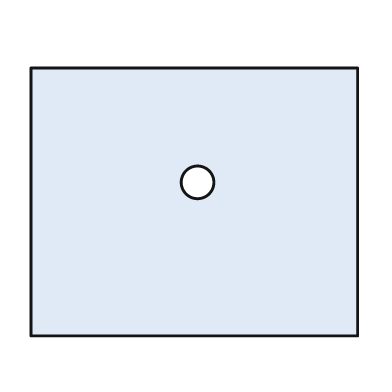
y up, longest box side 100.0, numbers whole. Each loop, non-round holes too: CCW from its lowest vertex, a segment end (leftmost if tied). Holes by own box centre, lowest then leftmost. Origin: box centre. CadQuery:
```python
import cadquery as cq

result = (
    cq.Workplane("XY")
    .moveTo(-50.0, -41.0)
    .lineTo(50.0, -41.0)
    .lineTo(50.0, 41.0)
    .lineTo(-50.0, 41.0)
    .close()
    .moveTo(1.0, 6.0)
    .circle(5.0)
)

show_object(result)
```